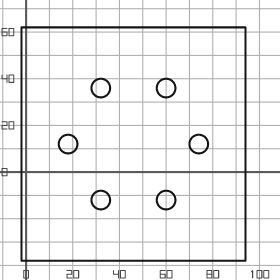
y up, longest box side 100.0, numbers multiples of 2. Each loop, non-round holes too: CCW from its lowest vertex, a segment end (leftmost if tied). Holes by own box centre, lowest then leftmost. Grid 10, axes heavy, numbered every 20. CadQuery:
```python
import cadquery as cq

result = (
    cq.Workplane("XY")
    .moveTo(-2.0, -38.0)
    .lineTo(94.0, -38.0)
    .lineTo(94.0, 62.0)
    .lineTo(-2.0, 62.0)
    .close()
    .moveTo(32.0, -12.0)
    .circle(4.0)
    .moveTo(60.0, -12.0)
    .circle(4.0)
    .moveTo(18.0, 12.0)
    .circle(4.0)
    .moveTo(74.0, 12.0)
    .circle(4.0)
    .moveTo(32.0, 36.0)
    .circle(4.0)
    .moveTo(60.0, 36.0)
    .circle(4.0)
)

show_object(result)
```